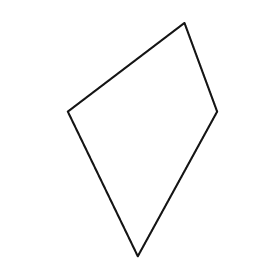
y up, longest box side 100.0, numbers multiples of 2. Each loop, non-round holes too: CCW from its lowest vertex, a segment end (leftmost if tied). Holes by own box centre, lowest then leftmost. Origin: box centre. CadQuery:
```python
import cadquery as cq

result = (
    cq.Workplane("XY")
    .moveTo(-2.0, -50.0)
    .lineTo(32.0, 12.0)
    .lineTo(18.0, 50.0)
    .lineTo(-32.0, 12.0)
    .close()
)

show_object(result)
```